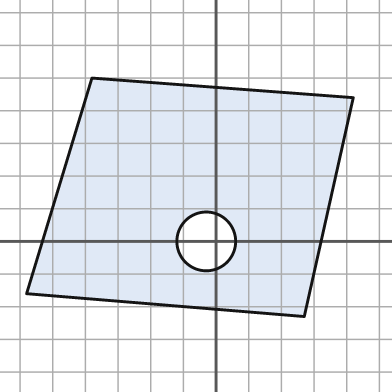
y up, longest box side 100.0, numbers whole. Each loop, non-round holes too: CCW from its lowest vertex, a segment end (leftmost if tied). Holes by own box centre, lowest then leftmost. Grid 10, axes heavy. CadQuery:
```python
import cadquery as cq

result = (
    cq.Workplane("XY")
    .moveTo(27.0, -23.0)
    .lineTo(42.0, 44.0)
    .lineTo(-38.0, 50.0)
    .lineTo(-58.0, -16.0)
    .close()
    .moveTo(-3.0, 0.0)
    .circle(9.0)
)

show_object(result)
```